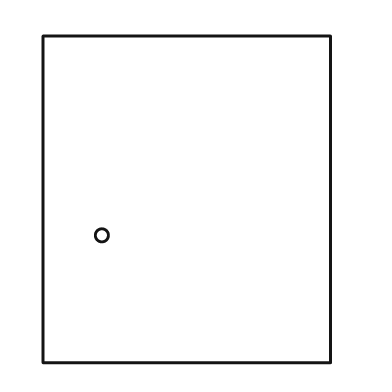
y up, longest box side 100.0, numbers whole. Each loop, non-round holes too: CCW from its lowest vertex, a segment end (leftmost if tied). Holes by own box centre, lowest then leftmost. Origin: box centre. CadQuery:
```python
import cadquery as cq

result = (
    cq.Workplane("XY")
    .moveTo(-44.0, -50.0)
    .lineTo(44.0, -50.0)
    .lineTo(44.0, 50.0)
    .lineTo(-44.0, 50.0)
    .close()
    .moveTo(-26.0, -11.0)
    .circle(2.0)
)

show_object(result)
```